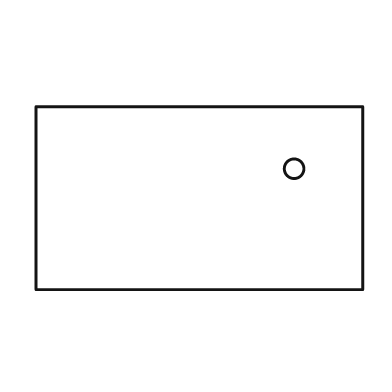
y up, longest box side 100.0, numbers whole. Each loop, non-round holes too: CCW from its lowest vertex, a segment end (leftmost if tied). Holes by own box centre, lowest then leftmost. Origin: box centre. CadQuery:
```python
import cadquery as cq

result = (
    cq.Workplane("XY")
    .moveTo(-50.0, -28.0)
    .lineTo(50.0, -28.0)
    .lineTo(50.0, 28.0)
    .lineTo(-50.0, 28.0)
    .close()
    .moveTo(29.0, 9.0)
    .circle(3.0)
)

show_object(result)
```